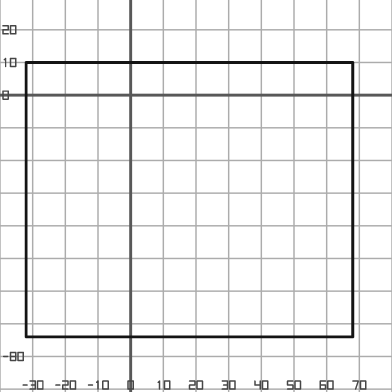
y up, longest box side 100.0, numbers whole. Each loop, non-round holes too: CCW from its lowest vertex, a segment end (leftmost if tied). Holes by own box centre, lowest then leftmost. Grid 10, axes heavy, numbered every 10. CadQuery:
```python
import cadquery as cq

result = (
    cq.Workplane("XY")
    .moveTo(-32.0, -74.0)
    .lineTo(68.0, -74.0)
    .lineTo(68.0, 10.0)
    .lineTo(-32.0, 10.0)
    .close()
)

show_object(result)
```